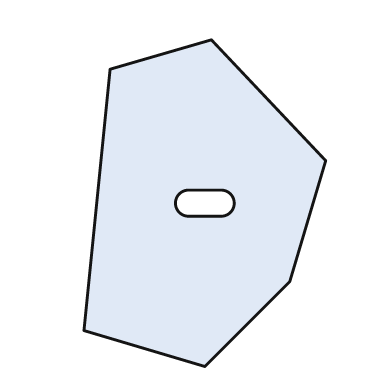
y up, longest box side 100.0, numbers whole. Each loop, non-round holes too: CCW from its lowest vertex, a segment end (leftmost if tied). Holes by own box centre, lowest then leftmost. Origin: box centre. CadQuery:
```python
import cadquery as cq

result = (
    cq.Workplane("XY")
    .moveTo(0.0, -50.0)
    .lineTo(26.0, -24.0)
    .lineTo(37.0, 13.0)
    .lineTo(2.0, 50.0)
    .lineTo(-29.0, 41.0)
    .lineTo(-37.0, -39.0)
    .close()
    .moveTo(-5.0, -4.0)
    .lineTo(5.0, -4.0)
    .threePointArc((9.0, 0.0), (5.0, 4.0))
    .lineTo(-5.0, 4.0)
    .threePointArc((-9.0, 0.0), (-5.0, -4.0))
    .close()
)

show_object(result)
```